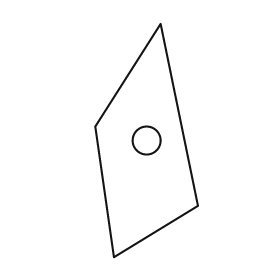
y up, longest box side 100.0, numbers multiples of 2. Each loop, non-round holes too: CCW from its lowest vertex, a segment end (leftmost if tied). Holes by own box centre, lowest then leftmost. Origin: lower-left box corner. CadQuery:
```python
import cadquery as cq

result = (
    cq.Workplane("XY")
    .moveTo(8.0, 0.0)
    .lineTo(44.0, 22.0)
    .lineTo(28.0, 100.0)
    .lineTo(0.0, 56.0)
    .close()
    .moveTo(22.0, 50.0)
    .circle(6.0)
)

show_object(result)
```